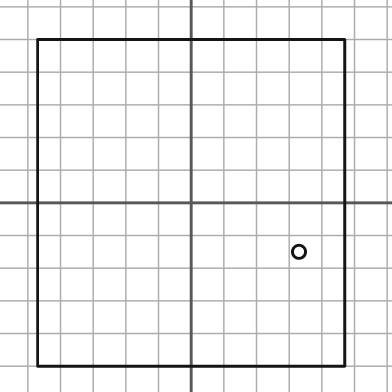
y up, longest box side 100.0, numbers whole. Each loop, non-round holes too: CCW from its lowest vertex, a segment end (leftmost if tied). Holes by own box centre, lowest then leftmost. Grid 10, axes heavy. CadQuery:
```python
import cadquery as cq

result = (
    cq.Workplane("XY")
    .moveTo(-47.0, -50.0)
    .lineTo(47.0, -50.0)
    .lineTo(47.0, 50.0)
    .lineTo(-47.0, 50.0)
    .close()
    .moveTo(33.0, -15.0)
    .circle(2.0)
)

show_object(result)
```